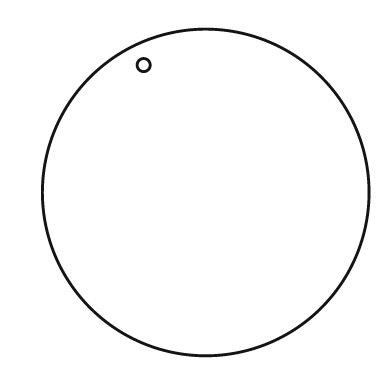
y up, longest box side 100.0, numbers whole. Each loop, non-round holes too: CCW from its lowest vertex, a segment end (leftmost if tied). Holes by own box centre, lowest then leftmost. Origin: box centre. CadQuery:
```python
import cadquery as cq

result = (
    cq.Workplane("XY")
    .moveTo(0.0, 0.0)
    .circle(50.0)
    .moveTo(-19.0, 39.0)
    .circle(2.0)
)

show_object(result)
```